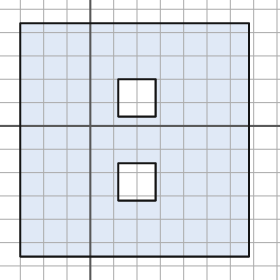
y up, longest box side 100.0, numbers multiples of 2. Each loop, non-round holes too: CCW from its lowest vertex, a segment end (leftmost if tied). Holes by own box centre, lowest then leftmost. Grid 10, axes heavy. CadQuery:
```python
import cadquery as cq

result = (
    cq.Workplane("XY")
    .moveTo(-30.0, -56.0)
    .lineTo(68.0, -56.0)
    .lineTo(68.0, 44.0)
    .lineTo(-30.0, 44.0)
    .close()
    .moveTo(12.0, -32.0)
    .lineTo(28.0, -32.0)
    .lineTo(28.0, -16.0)
    .lineTo(12.0, -16.0)
    .close()
    .moveTo(12.0, 4.0)
    .lineTo(28.0, 4.0)
    .lineTo(28.0, 20.0)
    .lineTo(12.0, 20.0)
    .close()
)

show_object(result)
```